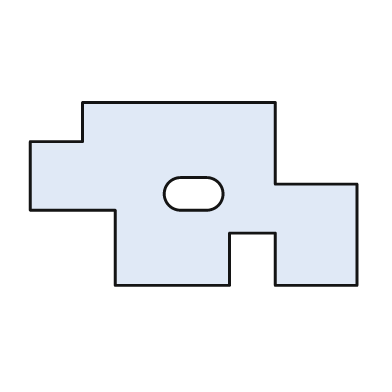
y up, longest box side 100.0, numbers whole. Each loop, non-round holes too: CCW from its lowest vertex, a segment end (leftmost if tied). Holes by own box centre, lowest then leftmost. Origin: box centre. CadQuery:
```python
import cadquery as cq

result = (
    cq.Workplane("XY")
    .moveTo(-24.0, -28.0)
    .lineTo(11.0, -28.0)
    .lineTo(11.0, -12.0)
    .lineTo(25.0, -12.0)
    .lineTo(25.0, -28.0)
    .lineTo(50.0, -28.0)
    .lineTo(50.0, 3.0)
    .lineTo(25.0, 3.0)
    .lineTo(25.0, 28.0)
    .lineTo(-34.0, 28.0)
    .lineTo(-34.0, 16.0)
    .lineTo(-50.0, 16.0)
    .lineTo(-50.0, -5.0)
    .lineTo(-24.0, -5.0)
    .close()
    .moveTo(-4.0, -5.0)
    .lineTo(4.0, -5.0)
    .threePointArc((9.0, 0.0), (4.0, 5.0))
    .lineTo(-4.0, 5.0)
    .threePointArc((-9.0, 0.0), (-4.0, -5.0))
    .close()
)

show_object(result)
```